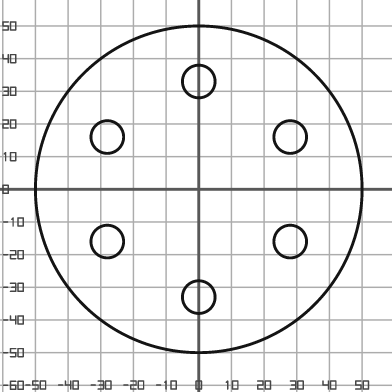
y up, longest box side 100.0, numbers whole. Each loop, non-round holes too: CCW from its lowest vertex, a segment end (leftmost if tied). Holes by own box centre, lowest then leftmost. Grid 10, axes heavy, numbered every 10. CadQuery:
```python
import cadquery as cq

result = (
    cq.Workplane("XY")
    .moveTo(0.0, 0.0)
    .circle(50.0)
    .moveTo(0.0, -33.0)
    .circle(5.0)
    .moveTo(-28.0, -16.0)
    .circle(5.0)
    .moveTo(28.0, -16.0)
    .circle(5.0)
    .moveTo(-28.0, 16.0)
    .circle(5.0)
    .moveTo(28.0, 16.0)
    .circle(5.0)
    .moveTo(0.0, 33.0)
    .circle(5.0)
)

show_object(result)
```